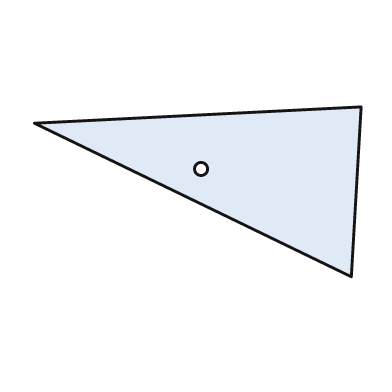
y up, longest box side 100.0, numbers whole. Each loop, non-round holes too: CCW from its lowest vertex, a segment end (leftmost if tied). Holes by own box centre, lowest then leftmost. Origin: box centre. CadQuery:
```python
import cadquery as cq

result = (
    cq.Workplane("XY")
    .moveTo(47.0, -26.0)
    .lineTo(50.0, 26.0)
    .lineTo(-50.0, 21.0)
    .close()
    .moveTo(1.0, 7.0)
    .circle(2.0)
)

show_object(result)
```